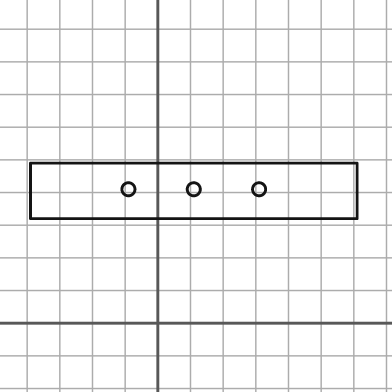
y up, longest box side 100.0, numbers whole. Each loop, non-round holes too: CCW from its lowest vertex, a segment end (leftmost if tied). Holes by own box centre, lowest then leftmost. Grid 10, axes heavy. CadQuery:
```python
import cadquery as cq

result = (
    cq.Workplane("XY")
    .moveTo(-39.0, 32.0)
    .lineTo(61.0, 32.0)
    .lineTo(61.0, 49.0)
    .lineTo(-39.0, 49.0)
    .close()
    .moveTo(-9.0, 41.0)
    .circle(2.0)
    .moveTo(11.0, 41.0)
    .circle(2.0)
    .moveTo(31.0, 41.0)
    .circle(2.0)
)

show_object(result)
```